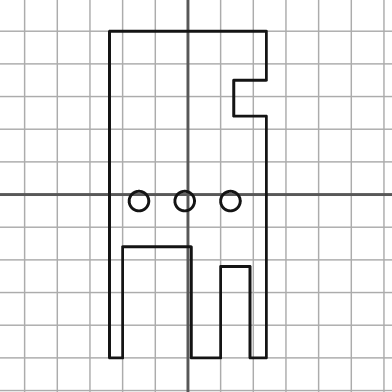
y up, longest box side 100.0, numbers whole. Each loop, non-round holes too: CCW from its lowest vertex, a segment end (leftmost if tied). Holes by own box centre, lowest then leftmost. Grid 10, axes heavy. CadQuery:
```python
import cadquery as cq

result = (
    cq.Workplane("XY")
    .moveTo(-24.0, -50.0)
    .lineTo(-20.0, -50.0)
    .lineTo(-20.0, -16.0)
    .lineTo(1.0, -16.0)
    .lineTo(1.0, -50.0)
    .lineTo(10.0, -50.0)
    .lineTo(10.0, -22.0)
    .lineTo(19.0, -22.0)
    .lineTo(19.0, -50.0)
    .lineTo(24.0, -50.0)
    .lineTo(24.0, 24.0)
    .lineTo(14.0, 24.0)
    .lineTo(14.0, 35.0)
    .lineTo(24.0, 35.0)
    .lineTo(24.0, 50.0)
    .lineTo(-24.0, 50.0)
    .close()
    .moveTo(-15.0, -2.0)
    .circle(3.0)
    .moveTo(-1.0, -2.0)
    .circle(3.0)
    .moveTo(13.0, -2.0)
    .circle(3.0)
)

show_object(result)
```